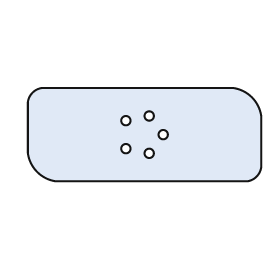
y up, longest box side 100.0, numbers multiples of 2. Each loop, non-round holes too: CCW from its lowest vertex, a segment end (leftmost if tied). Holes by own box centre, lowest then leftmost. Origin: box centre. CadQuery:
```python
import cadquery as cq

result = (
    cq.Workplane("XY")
    .moveTo(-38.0, -20.0)
    .lineTo(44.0, -20.0)
    .threePointArc((48.0, -18.0), (50.0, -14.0))
    .lineTo(50.0, 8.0)
    .threePointArc((46.0, 16.0), (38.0, 20.0))
    .lineTo(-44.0, 20.0)
    .threePointArc((-48.0, 18.0), (-50.0, 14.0))
    .lineTo(-50.0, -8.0)
    .threePointArc((-46.0, -16.0), (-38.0, -20.0))
    .close()
    .moveTo(2.0, -8.0)
    .circle(2.0)
    .moveTo(-8.0, -6.0)
    .circle(2.0)
    .moveTo(8.0, 0.0)
    .circle(2.0)
    .moveTo(-8.0, 6.0)
    .circle(2.0)
    .moveTo(2.0, 8.0)
    .circle(2.0)
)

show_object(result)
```